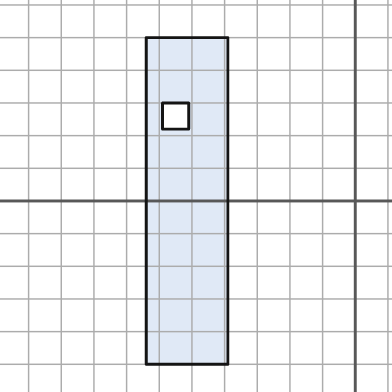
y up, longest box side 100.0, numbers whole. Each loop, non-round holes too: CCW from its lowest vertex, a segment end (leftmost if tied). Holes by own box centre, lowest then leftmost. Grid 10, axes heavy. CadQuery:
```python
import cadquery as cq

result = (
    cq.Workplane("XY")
    .moveTo(-64.0, -50.0)
    .lineTo(-39.0, -50.0)
    .lineTo(-39.0, 50.0)
    .lineTo(-64.0, 50.0)
    .close()
    .moveTo(-59.0, 22.0)
    .lineTo(-51.0, 22.0)
    .lineTo(-51.0, 30.0)
    .lineTo(-59.0, 30.0)
    .close()
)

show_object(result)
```